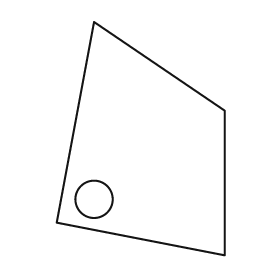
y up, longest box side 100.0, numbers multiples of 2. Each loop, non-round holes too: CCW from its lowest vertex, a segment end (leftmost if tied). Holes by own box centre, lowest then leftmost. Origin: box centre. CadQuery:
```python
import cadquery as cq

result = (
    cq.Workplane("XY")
    .moveTo(36.0, -50.0)
    .lineTo(36.0, 12.0)
    .lineTo(-20.0, 50.0)
    .lineTo(-36.0, -36.0)
    .close()
    .moveTo(-20.0, -26.0)
    .circle(8.0)
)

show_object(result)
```